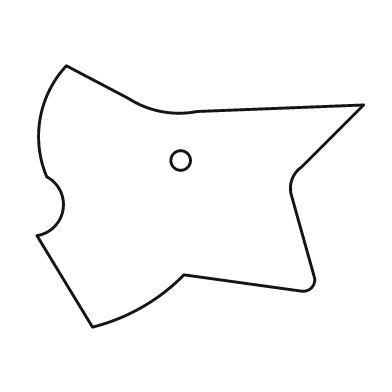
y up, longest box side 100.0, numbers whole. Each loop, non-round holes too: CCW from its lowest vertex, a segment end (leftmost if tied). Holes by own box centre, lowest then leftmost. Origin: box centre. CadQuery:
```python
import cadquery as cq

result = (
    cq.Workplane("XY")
    .moveTo(-33.0, -40.0)
    .threePointArc((-18.0, -34.0), (-5.0, -24.0))
    .lineTo(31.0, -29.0)
    .threePointArc((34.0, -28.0), (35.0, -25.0))
    .lineTo(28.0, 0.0)
    .threePointArc((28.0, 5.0), (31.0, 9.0))
    .lineTo(50.0, 28.0)
    .lineTo(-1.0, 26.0)
    .threePointArc((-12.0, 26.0), (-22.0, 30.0))
    .lineTo(-41.0, 40.0)
    .threePointArc((-49.0, 24.0), (-47.0, 6.0))
    .threePointArc((-42.0, -4.0), (-50.0, -12.0))
    .close()
    .moveTo(-6.0, 11.0)
    .circle(3.0)
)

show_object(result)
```